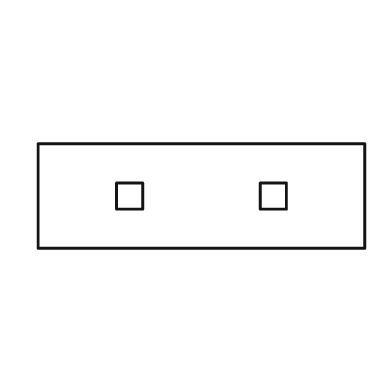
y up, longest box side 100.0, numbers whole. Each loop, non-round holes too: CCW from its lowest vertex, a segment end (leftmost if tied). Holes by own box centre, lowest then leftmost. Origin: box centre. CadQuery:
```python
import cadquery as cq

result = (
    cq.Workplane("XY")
    .moveTo(-50.0, -16.0)
    .lineTo(50.0, -16.0)
    .lineTo(50.0, 16.0)
    .lineTo(-50.0, 16.0)
    .close()
    .moveTo(-26.0, -4.0)
    .lineTo(-18.0, -4.0)
    .lineTo(-18.0, 4.0)
    .lineTo(-26.0, 4.0)
    .close()
    .moveTo(18.0, -4.0)
    .lineTo(26.0, -4.0)
    .lineTo(26.0, 4.0)
    .lineTo(18.0, 4.0)
    .close()
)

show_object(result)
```